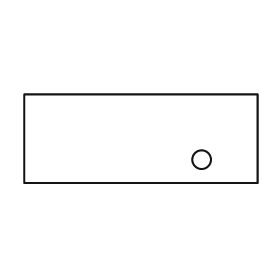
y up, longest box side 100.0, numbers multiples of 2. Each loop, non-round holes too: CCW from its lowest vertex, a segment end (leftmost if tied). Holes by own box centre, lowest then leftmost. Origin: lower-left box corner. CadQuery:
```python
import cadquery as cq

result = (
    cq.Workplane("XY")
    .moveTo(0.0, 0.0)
    .lineTo(100.0, 0.0)
    .lineTo(100.0, 38.0)
    .lineTo(0.0, 38.0)
    .close()
    .moveTo(76.0, 10.0)
    .circle(4.0)
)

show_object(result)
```